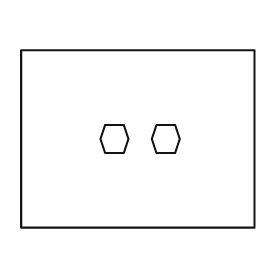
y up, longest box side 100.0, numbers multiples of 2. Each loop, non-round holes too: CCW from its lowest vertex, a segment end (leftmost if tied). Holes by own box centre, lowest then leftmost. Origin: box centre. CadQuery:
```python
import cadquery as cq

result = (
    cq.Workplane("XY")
    .moveTo(-50.0, -38.0)
    .lineTo(50.0, -38.0)
    .lineTo(50.0, 38.0)
    .lineTo(-50.0, 38.0)
    .close()
    .moveTo(-14.0, -6.0)
    .lineTo(-6.0, -6.0)
    .lineTo(-4.0, 0.0)
    .lineTo(-6.0, 6.0)
    .lineTo(-14.0, 6.0)
    .lineTo(-16.0, 0.0)
    .close()
    .moveTo(8.0, -6.0)
    .lineTo(16.0, -6.0)
    .lineTo(18.0, 0.0)
    .lineTo(16.0, 6.0)
    .lineTo(8.0, 6.0)
    .lineTo(6.0, 0.0)
    .close()
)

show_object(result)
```